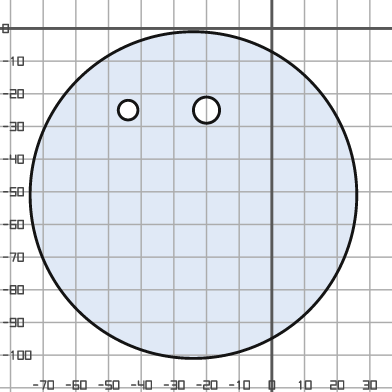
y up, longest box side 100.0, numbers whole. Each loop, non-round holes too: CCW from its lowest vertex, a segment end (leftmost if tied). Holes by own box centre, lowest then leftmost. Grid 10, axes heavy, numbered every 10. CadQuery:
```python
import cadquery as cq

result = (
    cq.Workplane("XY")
    .moveTo(-24.0, -51.0)
    .circle(50.0)
    .moveTo(-44.0, -25.0)
    .circle(3.0)
    .moveTo(-20.0, -25.0)
    .circle(4.0)
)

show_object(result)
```